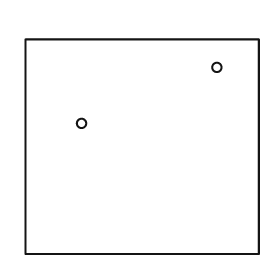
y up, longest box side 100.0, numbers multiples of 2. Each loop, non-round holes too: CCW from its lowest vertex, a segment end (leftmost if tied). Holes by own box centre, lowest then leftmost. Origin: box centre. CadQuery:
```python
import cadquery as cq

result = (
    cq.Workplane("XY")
    .moveTo(-50.0, -46.0)
    .lineTo(50.0, -46.0)
    .lineTo(50.0, 46.0)
    .lineTo(-50.0, 46.0)
    .close()
    .moveTo(-26.0, 10.0)
    .circle(2.0)
    .moveTo(32.0, 34.0)
    .circle(2.0)
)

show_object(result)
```